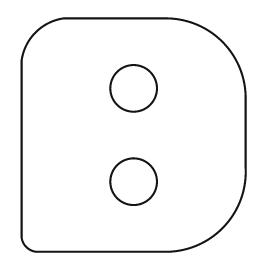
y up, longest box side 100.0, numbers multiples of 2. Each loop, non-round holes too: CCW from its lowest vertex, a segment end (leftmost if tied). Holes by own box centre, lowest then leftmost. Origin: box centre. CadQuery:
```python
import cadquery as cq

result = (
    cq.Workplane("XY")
    .moveTo(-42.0, -50.0)
    .lineTo(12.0, -50.0)
    .threePointArc((38.0, -40.0), (48.0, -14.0))
    .lineTo(48.0, 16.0)
    .threePointArc((38.0, 40.0), (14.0, 50.0))
    .lineTo(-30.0, 50.0)
    .threePointArc((-42.0, 44.0), (-48.0, 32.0))
    .lineTo(-48.0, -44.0)
    .threePointArc((-46.0, -48.0), (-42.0, -50.0))
    .close()
    .moveTo(0.0, -20.0)
    .circle(10.0)
    .moveTo(0.0, 20.0)
    .circle(10.0)
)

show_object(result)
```